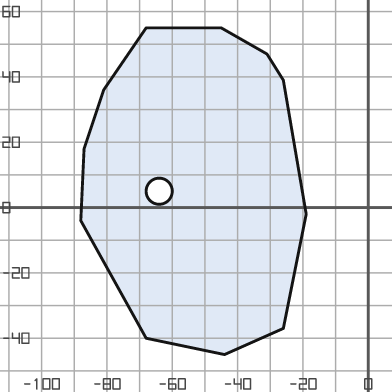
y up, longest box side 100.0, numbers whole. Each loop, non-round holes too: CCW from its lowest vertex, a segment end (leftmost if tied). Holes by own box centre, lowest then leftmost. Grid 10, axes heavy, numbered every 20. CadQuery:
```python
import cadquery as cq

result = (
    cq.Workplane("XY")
    .moveTo(-44.0, -45.0)
    .lineTo(-26.0, -37.0)
    .lineTo(-19.0, -2.0)
    .lineTo(-26.0, 39.0)
    .lineTo(-31.0, 47.0)
    .lineTo(-45.0, 55.0)
    .lineTo(-68.0, 55.0)
    .lineTo(-81.0, 36.0)
    .lineTo(-87.0, 18.0)
    .lineTo(-88.0, -4.0)
    .lineTo(-68.0, -40.0)
    .close()
    .moveTo(-64.0, 5.0)
    .circle(4.0)
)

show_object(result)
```